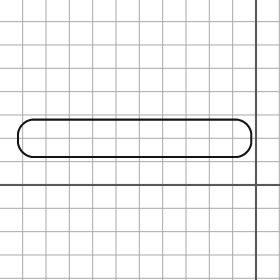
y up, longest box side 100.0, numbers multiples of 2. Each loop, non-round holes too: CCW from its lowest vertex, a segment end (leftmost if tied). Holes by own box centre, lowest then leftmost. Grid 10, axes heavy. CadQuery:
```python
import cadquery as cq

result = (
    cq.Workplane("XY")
    .moveTo(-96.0, 12.0)
    .lineTo(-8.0, 12.0)
    .threePointArc((-4.0, 14.0), (-2.0, 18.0))
    .lineTo(-2.0, 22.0)
    .threePointArc((-4.0, 26.0), (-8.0, 28.0))
    .lineTo(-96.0, 28.0)
    .threePointArc((-100.0, 26.0), (-102.0, 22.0))
    .lineTo(-102.0, 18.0)
    .threePointArc((-100.0, 14.0), (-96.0, 12.0))
    .close()
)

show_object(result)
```